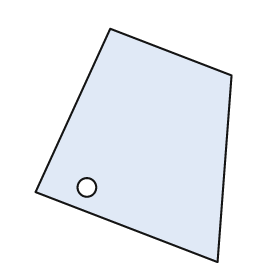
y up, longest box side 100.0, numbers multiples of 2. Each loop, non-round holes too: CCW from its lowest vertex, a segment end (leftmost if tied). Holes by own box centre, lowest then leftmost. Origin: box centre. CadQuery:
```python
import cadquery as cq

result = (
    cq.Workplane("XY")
    .moveTo(36.0, -50.0)
    .lineTo(42.0, 30.0)
    .lineTo(-10.0, 50.0)
    .lineTo(-42.0, -20.0)
    .close()
    .moveTo(-20.0, -18.0)
    .circle(4.0)
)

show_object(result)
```